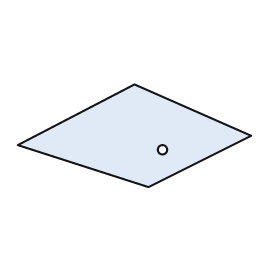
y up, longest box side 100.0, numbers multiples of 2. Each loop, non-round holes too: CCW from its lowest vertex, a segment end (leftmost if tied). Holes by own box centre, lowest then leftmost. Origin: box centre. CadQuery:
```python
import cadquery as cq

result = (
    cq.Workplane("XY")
    .moveTo(6.0, -22.0)
    .lineTo(50.0, 0.0)
    .lineTo(0.0, 22.0)
    .lineTo(-50.0, -4.0)
    .close()
    .moveTo(12.0, -6.0)
    .circle(2.0)
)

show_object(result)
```